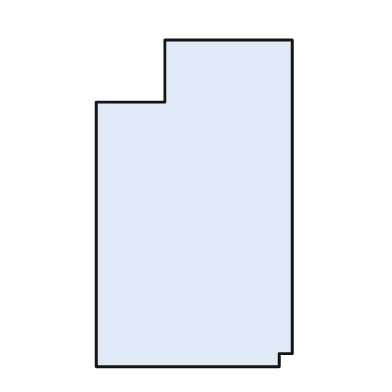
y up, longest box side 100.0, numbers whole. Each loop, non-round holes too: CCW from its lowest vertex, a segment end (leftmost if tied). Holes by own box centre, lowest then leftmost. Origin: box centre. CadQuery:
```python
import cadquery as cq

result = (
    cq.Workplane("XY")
    .moveTo(-30.0, -50.0)
    .lineTo(26.0, -50.0)
    .lineTo(26.0, -46.0)
    .lineTo(30.0, -46.0)
    .lineTo(30.0, 50.0)
    .lineTo(-9.0, 50.0)
    .lineTo(-9.0, 31.0)
    .lineTo(-30.0, 31.0)
    .close()
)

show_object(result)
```